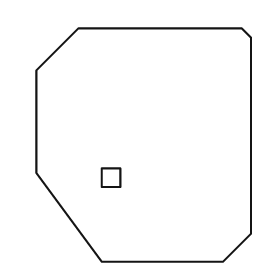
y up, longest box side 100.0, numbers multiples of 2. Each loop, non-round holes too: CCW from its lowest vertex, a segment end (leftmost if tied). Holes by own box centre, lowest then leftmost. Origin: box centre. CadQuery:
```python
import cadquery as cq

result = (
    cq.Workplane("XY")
    .moveTo(-18.0, -50.0)
    .lineTo(34.0, -50.0)
    .lineTo(46.0, -38.0)
    .lineTo(46.0, 46.0)
    .lineTo(42.0, 50.0)
    .lineTo(-28.0, 50.0)
    .lineTo(-46.0, 32.0)
    .lineTo(-46.0, -12.0)
    .close()
    .moveTo(-18.0, -18.0)
    .lineTo(-10.0, -18.0)
    .lineTo(-10.0, -10.0)
    .lineTo(-18.0, -10.0)
    .close()
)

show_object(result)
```